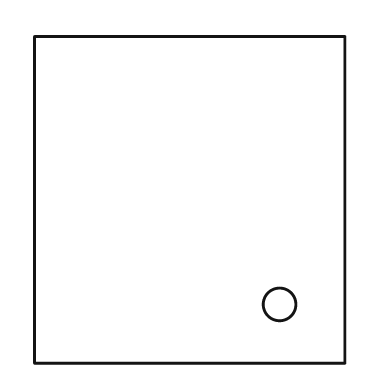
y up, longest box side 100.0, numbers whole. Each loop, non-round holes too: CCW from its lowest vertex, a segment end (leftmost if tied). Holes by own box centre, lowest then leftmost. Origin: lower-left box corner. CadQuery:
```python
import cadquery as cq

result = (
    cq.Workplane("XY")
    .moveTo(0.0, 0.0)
    .lineTo(95.0, 0.0)
    .lineTo(95.0, 100.0)
    .lineTo(0.0, 100.0)
    .close()
    .moveTo(75.0, 18.0)
    .circle(5.0)
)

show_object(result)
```